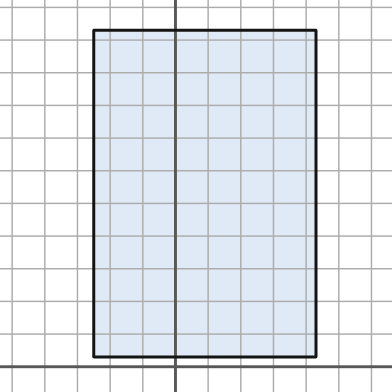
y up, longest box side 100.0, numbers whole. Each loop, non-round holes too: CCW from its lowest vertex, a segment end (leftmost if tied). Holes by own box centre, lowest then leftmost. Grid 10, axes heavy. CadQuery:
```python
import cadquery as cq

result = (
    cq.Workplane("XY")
    .moveTo(-25.0, 3.0)
    .lineTo(43.0, 3.0)
    .lineTo(43.0, 103.0)
    .lineTo(-25.0, 103.0)
    .close()
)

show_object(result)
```